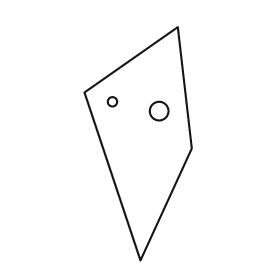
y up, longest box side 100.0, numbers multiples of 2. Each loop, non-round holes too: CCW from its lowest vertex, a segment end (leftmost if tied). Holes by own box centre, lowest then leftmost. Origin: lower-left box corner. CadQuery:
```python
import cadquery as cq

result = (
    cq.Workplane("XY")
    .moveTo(24.0, 0.0)
    .lineTo(46.0, 48.0)
    .lineTo(40.0, 100.0)
    .lineTo(0.0, 72.0)
    .close()
    .moveTo(32.0, 64.0)
    .circle(4.0)
    .moveTo(12.0, 68.0)
    .circle(2.0)
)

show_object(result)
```